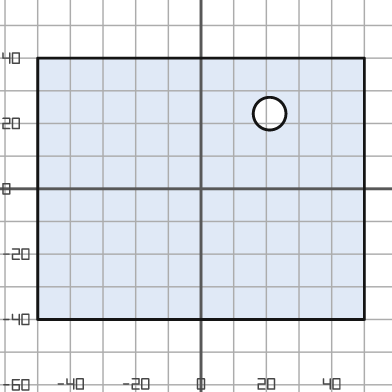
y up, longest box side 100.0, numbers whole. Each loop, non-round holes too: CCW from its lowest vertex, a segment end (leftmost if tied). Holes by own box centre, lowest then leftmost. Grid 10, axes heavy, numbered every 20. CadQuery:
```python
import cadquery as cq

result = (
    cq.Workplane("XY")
    .moveTo(-50.0, -40.0)
    .lineTo(50.0, -40.0)
    .lineTo(50.0, 40.0)
    .lineTo(-50.0, 40.0)
    .close()
    .moveTo(21.0, 23.0)
    .circle(5.0)
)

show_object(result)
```